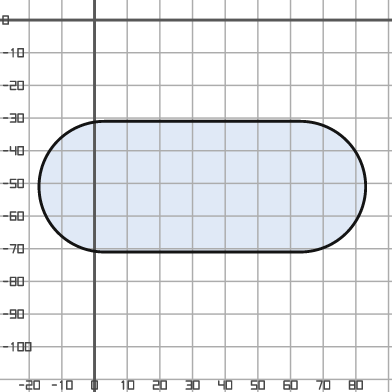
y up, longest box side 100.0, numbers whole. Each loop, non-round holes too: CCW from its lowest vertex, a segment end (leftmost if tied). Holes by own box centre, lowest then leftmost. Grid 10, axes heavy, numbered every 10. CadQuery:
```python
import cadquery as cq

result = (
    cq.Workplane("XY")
    .moveTo(3.0, -71.0)
    .lineTo(63.0, -71.0)
    .threePointArc((83.0, -51.0), (63.0, -31.0))
    .lineTo(3.0, -31.0)
    .threePointArc((-17.0, -51.0), (3.0, -71.0))
    .close()
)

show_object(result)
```